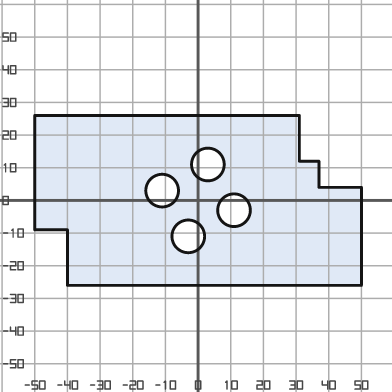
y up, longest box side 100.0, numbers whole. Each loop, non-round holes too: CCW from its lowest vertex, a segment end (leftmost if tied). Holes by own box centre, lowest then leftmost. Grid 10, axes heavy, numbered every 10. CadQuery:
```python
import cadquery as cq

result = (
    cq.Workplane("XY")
    .moveTo(-40.0, -26.0)
    .lineTo(50.0, -26.0)
    .lineTo(50.0, 4.0)
    .lineTo(37.0, 4.0)
    .lineTo(37.0, 12.0)
    .lineTo(31.0, 12.0)
    .lineTo(31.0, 26.0)
    .lineTo(-50.0, 26.0)
    .lineTo(-50.0, -9.0)
    .lineTo(-40.0, -9.0)
    .close()
    .moveTo(-3.0, -11.0)
    .circle(5.0)
    .moveTo(11.0, -3.0)
    .circle(5.0)
    .moveTo(-11.0, 3.0)
    .circle(5.0)
    .moveTo(3.0, 11.0)
    .circle(5.0)
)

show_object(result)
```